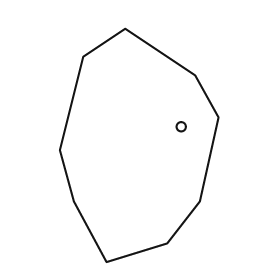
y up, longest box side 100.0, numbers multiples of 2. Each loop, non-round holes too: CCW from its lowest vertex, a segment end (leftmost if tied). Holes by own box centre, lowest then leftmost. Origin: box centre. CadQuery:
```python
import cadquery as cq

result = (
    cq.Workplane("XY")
    .moveTo(-14.0, -50.0)
    .lineTo(12.0, -42.0)
    .lineTo(26.0, -24.0)
    .lineTo(34.0, 12.0)
    .lineTo(24.0, 30.0)
    .lineTo(-6.0, 50.0)
    .lineTo(-24.0, 38.0)
    .lineTo(-34.0, -2.0)
    .lineTo(-28.0, -24.0)
    .close()
    .moveTo(18.0, 8.0)
    .circle(2.0)
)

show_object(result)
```